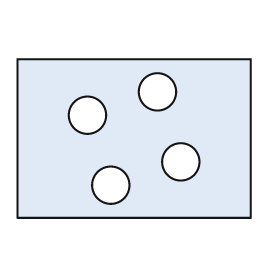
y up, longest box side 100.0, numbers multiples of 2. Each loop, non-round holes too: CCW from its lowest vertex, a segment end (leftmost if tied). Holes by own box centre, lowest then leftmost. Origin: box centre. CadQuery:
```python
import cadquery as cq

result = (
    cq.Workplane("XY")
    .moveTo(-50.0, -34.0)
    .lineTo(50.0, -34.0)
    .lineTo(50.0, 34.0)
    .lineTo(-50.0, 34.0)
    .close()
    .moveTo(-10.0, -20.0)
    .circle(8.0)
    .moveTo(20.0, -10.0)
    .circle(8.0)
    .moveTo(-20.0, 10.0)
    .circle(8.0)
    .moveTo(10.0, 20.0)
    .circle(8.0)
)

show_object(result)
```